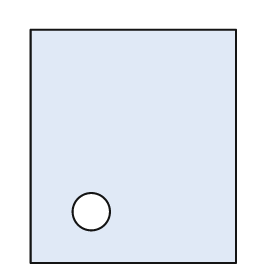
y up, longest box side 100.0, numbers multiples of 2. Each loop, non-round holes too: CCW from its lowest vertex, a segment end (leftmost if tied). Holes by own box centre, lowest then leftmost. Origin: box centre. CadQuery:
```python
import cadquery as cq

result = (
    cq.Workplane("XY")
    .moveTo(-44.0, -50.0)
    .lineTo(44.0, -50.0)
    .lineTo(44.0, 50.0)
    .lineTo(-44.0, 50.0)
    .close()
    .moveTo(-18.0, -28.0)
    .circle(8.0)
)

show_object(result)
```